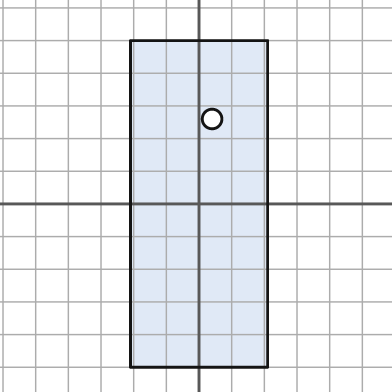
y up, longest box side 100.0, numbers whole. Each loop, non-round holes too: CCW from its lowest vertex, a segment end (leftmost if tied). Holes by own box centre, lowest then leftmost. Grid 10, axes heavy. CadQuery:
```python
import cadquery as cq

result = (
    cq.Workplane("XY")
    .moveTo(-21.0, -50.0)
    .lineTo(21.0, -50.0)
    .lineTo(21.0, 50.0)
    .lineTo(-21.0, 50.0)
    .close()
    .moveTo(4.0, 26.0)
    .circle(3.0)
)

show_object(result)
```